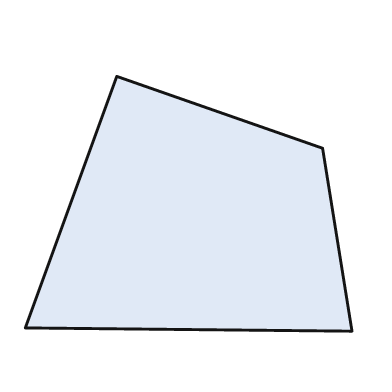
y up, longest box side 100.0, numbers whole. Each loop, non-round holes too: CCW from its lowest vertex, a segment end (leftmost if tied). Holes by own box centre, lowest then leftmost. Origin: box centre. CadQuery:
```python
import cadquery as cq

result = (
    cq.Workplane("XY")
    .moveTo(50.0, -39.0)
    .lineTo(41.0, 17.0)
    .lineTo(-22.0, 39.0)
    .lineTo(-50.0, -38.0)
    .close()
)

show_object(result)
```